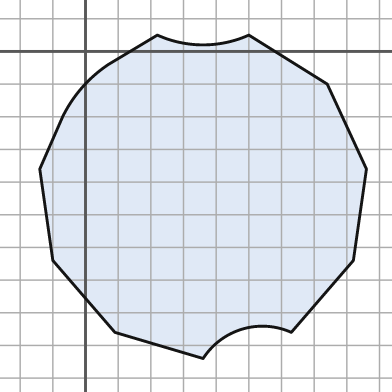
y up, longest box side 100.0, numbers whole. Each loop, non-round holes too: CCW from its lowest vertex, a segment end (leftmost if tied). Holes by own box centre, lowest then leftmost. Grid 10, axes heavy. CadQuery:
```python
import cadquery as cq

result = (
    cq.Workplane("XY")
    .moveTo(36.0, -94.0)
    .threePointArc((48.0, -85.0), (63.0, -86.0))
    .lineTo(82.0, -64.0)
    .lineTo(86.0, -36.0)
    .lineTo(74.0, -10.0)
    .lineTo(50.0, 5.0)
    .threePointArc((36.0, 2.0), (22.0, 5.0))
    .lineTo(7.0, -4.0)
    .threePointArc((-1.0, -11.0), (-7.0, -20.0))
    .lineTo(-14.0, -36.0)
    .lineTo(-10.0, -64.0)
    .lineTo(9.0, -86.0)
    .close()
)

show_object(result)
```